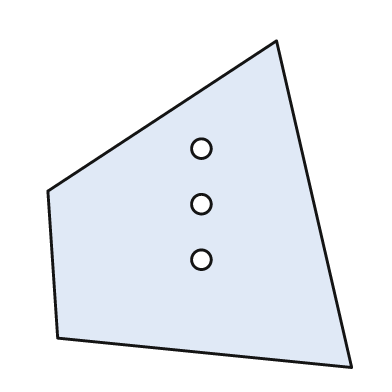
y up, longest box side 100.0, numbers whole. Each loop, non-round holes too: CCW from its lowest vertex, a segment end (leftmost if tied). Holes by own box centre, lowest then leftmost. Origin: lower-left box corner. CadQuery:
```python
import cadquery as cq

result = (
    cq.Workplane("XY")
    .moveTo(93.0, 0.0)
    .lineTo(70.0, 100.0)
    .lineTo(0.0, 54.0)
    .lineTo(3.0, 9.0)
    .close()
    .moveTo(47.0, 33.0)
    .circle(3.0)
    .moveTo(47.0, 50.0)
    .circle(3.0)
    .moveTo(47.0, 67.0)
    .circle(3.0)
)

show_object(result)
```